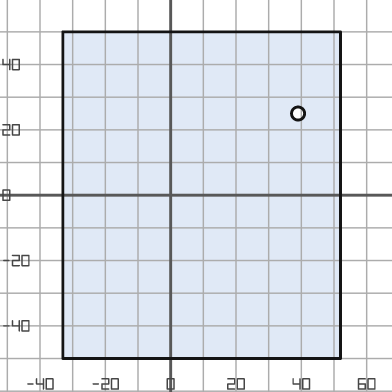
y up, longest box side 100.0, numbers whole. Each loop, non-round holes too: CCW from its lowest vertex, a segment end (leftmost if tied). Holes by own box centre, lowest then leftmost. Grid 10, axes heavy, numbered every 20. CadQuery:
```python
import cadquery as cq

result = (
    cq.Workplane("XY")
    .moveTo(-33.0, -50.0)
    .lineTo(52.0, -50.0)
    .lineTo(52.0, 50.0)
    .lineTo(-33.0, 50.0)
    .close()
    .moveTo(39.0, 25.0)
    .circle(2.0)
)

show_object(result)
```